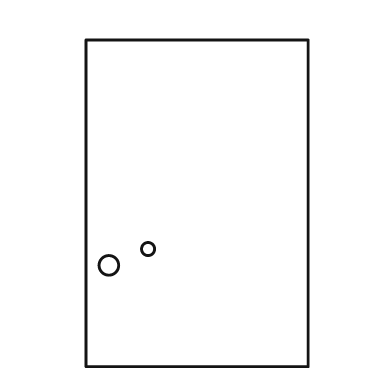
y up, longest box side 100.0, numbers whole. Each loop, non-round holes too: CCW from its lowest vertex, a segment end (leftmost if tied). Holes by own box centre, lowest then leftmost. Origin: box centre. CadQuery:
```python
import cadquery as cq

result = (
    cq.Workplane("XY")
    .moveTo(-34.0, -50.0)
    .lineTo(34.0, -50.0)
    .lineTo(34.0, 50.0)
    .lineTo(-34.0, 50.0)
    .close()
    .moveTo(-27.0, -19.0)
    .circle(3.0)
    .moveTo(-15.0, -14.0)
    .circle(2.0)
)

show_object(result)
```